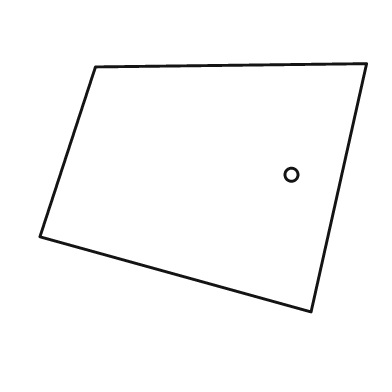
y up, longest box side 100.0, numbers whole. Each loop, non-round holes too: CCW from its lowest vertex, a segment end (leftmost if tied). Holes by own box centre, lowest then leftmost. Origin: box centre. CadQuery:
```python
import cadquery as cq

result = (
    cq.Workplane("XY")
    .moveTo(33.0, -38.0)
    .lineTo(50.0, 38.0)
    .lineTo(-33.0, 37.0)
    .lineTo(-50.0, -15.0)
    .close()
    .moveTo(27.0, 4.0)
    .circle(2.0)
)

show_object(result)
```